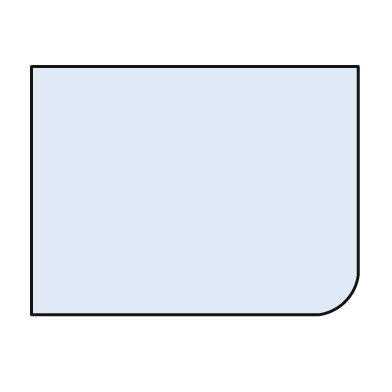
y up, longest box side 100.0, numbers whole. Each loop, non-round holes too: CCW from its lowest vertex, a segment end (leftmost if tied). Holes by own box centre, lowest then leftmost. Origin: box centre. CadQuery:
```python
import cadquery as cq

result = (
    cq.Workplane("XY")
    .moveTo(-50.0, -38.0)
    .lineTo(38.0, -38.0)
    .threePointArc((46.0, -34.0), (50.0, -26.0))
    .lineTo(50.0, 38.0)
    .lineTo(-50.0, 38.0)
    .close()
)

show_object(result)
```